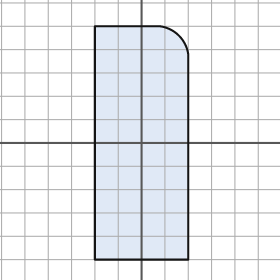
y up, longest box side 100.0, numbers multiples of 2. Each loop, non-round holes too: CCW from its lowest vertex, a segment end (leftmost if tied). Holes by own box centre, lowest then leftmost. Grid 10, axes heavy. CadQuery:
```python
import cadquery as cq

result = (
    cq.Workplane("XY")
    .moveTo(-20.0, -50.0)
    .lineTo(20.0, -50.0)
    .lineTo(20.0, 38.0)
    .threePointArc((16.0, 46.0), (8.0, 50.0))
    .lineTo(-20.0, 50.0)
    .close()
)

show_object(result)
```